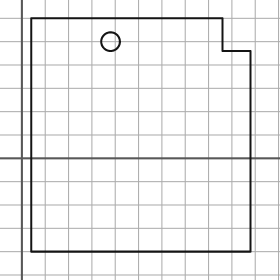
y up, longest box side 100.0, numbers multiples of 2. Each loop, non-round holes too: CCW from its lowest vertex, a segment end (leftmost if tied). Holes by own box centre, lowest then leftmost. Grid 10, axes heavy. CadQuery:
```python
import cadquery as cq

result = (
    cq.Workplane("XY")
    .moveTo(4.0, -40.0)
    .lineTo(98.0, -40.0)
    .lineTo(98.0, 46.0)
    .lineTo(86.0, 46.0)
    .lineTo(86.0, 60.0)
    .lineTo(4.0, 60.0)
    .close()
    .moveTo(38.0, 50.0)
    .circle(4.0)
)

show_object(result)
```